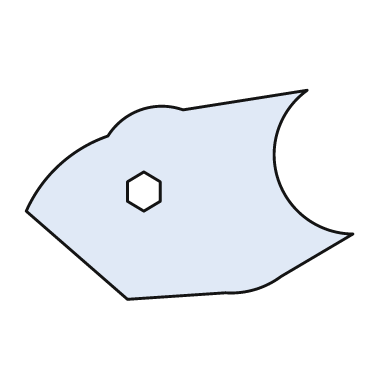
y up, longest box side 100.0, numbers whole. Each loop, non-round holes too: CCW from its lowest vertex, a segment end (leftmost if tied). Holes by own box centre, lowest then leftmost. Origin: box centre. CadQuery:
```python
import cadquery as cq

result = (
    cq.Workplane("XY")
    .moveTo(-19.0, -32.0)
    .lineTo(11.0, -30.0)
    .threePointArc((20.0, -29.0), (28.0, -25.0))
    .lineTo(50.0, -12.0)
    .threePointArc((27.0, 5.0), (36.0, 32.0))
    .lineTo(-2.0, 26.0)
    .threePointArc((-15.0, 26.0), (-25.0, 18.0))
    .threePointArc((-40.0, 9.0), (-50.0, -5.0))
    .close()
    .moveTo(-14.0, -5.0)
    .lineTo(-9.0, -2.0)
    .lineTo(-9.0, 4.0)
    .lineTo(-14.0, 7.0)
    .lineTo(-19.0, 4.0)
    .lineTo(-19.0, -2.0)
    .close()
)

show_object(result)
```